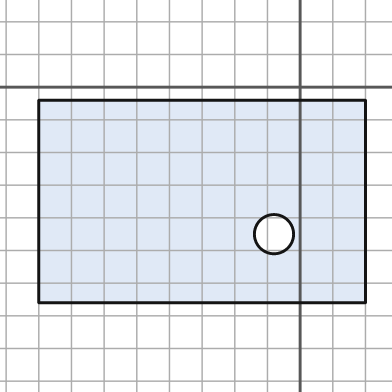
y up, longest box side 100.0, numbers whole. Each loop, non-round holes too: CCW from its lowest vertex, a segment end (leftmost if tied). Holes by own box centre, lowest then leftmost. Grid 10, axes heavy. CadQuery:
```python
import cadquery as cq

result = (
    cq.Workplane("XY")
    .moveTo(-80.0, -66.0)
    .lineTo(20.0, -66.0)
    .lineTo(20.0, -4.0)
    .lineTo(-80.0, -4.0)
    .close()
    .moveTo(-8.0, -45.0)
    .circle(6.0)
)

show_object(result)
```